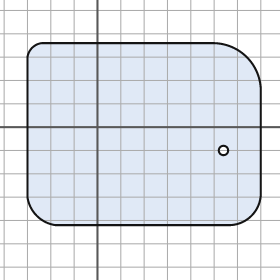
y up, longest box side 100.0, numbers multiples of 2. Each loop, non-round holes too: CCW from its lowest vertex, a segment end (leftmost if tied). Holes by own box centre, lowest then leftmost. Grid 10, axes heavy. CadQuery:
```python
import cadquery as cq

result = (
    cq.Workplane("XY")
    .moveTo(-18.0, -42.0)
    .lineTo(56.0, -42.0)
    .threePointArc((66.0, -38.0), (70.0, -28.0))
    .lineTo(70.0, 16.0)
    .threePointArc((64.0, 30.0), (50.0, 36.0))
    .lineTo(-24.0, 36.0)
    .threePointArc((-28.0, 34.0), (-30.0, 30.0))
    .lineTo(-30.0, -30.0)
    .threePointArc((-26.0, -38.0), (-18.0, -42.0))
    .close()
    .moveTo(54.0, -10.0)
    .circle(2.0)
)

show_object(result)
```